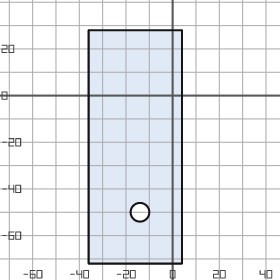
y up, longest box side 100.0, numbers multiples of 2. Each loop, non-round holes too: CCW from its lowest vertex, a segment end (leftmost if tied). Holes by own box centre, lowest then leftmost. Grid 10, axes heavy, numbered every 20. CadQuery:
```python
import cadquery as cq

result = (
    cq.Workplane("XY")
    .moveTo(-36.0, -72.0)
    .lineTo(4.0, -72.0)
    .lineTo(4.0, 28.0)
    .lineTo(-36.0, 28.0)
    .close()
    .moveTo(-14.0, -50.0)
    .circle(4.0)
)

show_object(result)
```